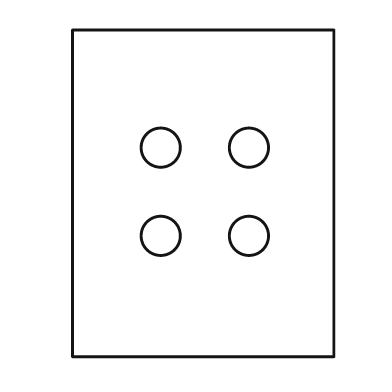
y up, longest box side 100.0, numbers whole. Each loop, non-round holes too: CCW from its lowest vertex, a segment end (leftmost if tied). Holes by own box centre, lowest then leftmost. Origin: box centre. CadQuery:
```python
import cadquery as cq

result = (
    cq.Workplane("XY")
    .moveTo(-40.0, -50.0)
    .lineTo(40.0, -50.0)
    .lineTo(40.0, 50.0)
    .lineTo(-40.0, 50.0)
    .close()
    .moveTo(-13.0, -13.0)
    .circle(6.0)
    .moveTo(14.0, -13.0)
    .circle(6.0)
    .moveTo(-13.0, 14.0)
    .circle(6.0)
    .moveTo(14.0, 14.0)
    .circle(6.0)
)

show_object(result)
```